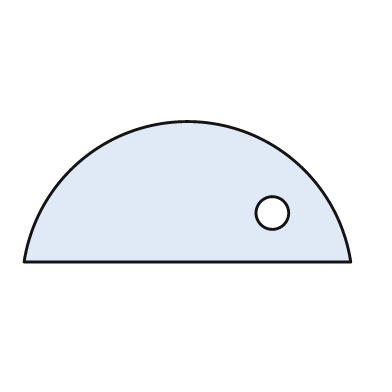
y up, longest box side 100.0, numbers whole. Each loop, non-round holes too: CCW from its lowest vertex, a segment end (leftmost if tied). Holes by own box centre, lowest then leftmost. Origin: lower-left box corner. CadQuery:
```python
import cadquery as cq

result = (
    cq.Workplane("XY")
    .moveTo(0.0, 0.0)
    .lineTo(100.0, 0.0)
    .threePointArc((50.0, 43.0), (0.0, 0.0))
    .close()
    .moveTo(76.0, 15.0)
    .circle(5.0)
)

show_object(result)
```